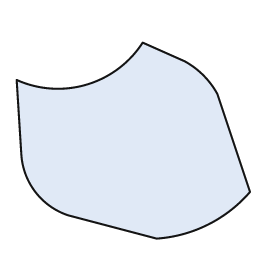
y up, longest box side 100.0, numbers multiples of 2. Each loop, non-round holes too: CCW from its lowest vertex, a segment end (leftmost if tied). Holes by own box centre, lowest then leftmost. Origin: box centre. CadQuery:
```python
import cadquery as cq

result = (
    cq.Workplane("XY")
    .moveTo(10.0, -42.0)
    .threePointArc((32.0, -36.0), (50.0, -22.0))
    .lineTo(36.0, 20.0)
    .threePointArc((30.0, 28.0), (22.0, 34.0))
    .lineTo(4.0, 42.0)
    .threePointArc((-20.0, 24.0), (-50.0, 26.0))
    .lineTo(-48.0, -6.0)
    .threePointArc((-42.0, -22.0), (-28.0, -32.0))
    .close()
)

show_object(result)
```